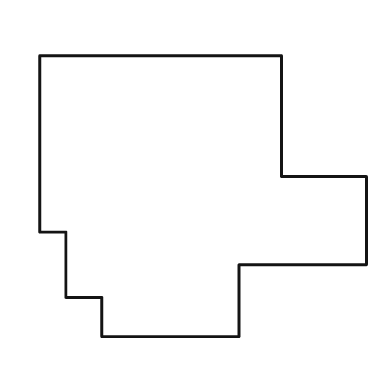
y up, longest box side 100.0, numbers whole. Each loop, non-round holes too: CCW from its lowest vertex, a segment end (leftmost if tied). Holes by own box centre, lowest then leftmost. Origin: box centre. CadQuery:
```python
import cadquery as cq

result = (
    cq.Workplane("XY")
    .moveTo(-31.0, -43.0)
    .lineTo(11.0, -43.0)
    .lineTo(11.0, -21.0)
    .lineTo(50.0, -21.0)
    .lineTo(50.0, 6.0)
    .lineTo(24.0, 6.0)
    .lineTo(24.0, 43.0)
    .lineTo(-50.0, 43.0)
    .lineTo(-50.0, -11.0)
    .lineTo(-42.0, -11.0)
    .lineTo(-42.0, -31.0)
    .lineTo(-31.0, -31.0)
    .close()
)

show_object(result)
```